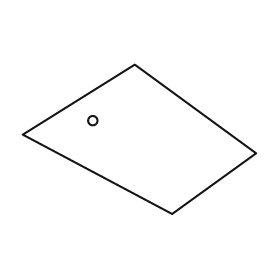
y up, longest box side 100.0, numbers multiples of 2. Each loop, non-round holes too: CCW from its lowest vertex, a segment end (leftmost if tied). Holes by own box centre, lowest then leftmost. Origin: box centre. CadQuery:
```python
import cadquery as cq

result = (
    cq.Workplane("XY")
    .moveTo(14.0, -32.0)
    .lineTo(50.0, -6.0)
    .lineTo(-2.0, 32.0)
    .lineTo(-50.0, 2.0)
    .close()
    .moveTo(-20.0, 8.0)
    .circle(2.0)
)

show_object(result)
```